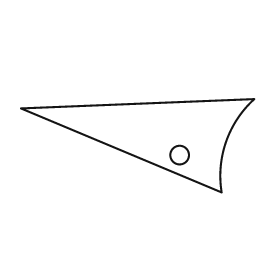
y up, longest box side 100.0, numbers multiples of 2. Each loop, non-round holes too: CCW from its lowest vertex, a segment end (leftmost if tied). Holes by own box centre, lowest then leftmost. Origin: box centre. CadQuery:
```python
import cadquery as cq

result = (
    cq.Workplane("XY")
    .moveTo(36.0, -20.0)
    .threePointArc((38.0, 2.0), (50.0, 20.0))
    .lineTo(-50.0, 16.0)
    .close()
    .moveTo(18.0, -4.0)
    .circle(4.0)
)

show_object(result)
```